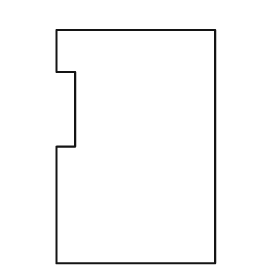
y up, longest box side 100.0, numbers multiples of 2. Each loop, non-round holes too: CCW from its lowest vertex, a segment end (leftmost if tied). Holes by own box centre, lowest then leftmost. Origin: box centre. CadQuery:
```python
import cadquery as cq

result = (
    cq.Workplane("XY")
    .moveTo(-34.0, -50.0)
    .lineTo(34.0, -50.0)
    .lineTo(34.0, 50.0)
    .lineTo(-34.0, 50.0)
    .lineTo(-34.0, 32.0)
    .lineTo(-26.0, 32.0)
    .lineTo(-26.0, 0.0)
    .lineTo(-34.0, 0.0)
    .close()
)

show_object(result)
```